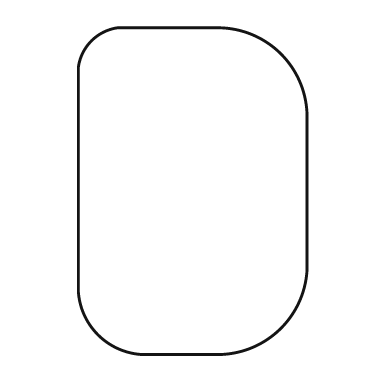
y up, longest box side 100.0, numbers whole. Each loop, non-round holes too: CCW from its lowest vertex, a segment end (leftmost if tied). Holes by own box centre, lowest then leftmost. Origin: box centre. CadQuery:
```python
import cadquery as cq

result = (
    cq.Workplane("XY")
    .moveTo(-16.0, -50.0)
    .lineTo(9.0, -50.0)
    .threePointArc((27.0, -42.0), (35.0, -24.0))
    .lineTo(35.0, 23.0)
    .threePointArc((27.0, 42.0), (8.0, 50.0))
    .lineTo(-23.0, 50.0)
    .threePointArc((-31.0, 46.0), (-35.0, 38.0))
    .lineTo(-35.0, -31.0)
    .threePointArc((-29.0, -44.0), (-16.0, -50.0))
    .close()
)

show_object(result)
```